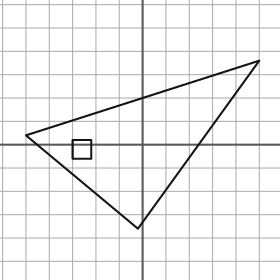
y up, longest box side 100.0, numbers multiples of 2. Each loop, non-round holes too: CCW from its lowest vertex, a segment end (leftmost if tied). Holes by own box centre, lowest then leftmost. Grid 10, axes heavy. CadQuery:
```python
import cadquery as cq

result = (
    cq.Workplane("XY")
    .moveTo(-2.0, -36.0)
    .lineTo(50.0, 36.0)
    .lineTo(-50.0, 4.0)
    .close()
    .moveTo(-30.0, -6.0)
    .lineTo(-22.0, -6.0)
    .lineTo(-22.0, 2.0)
    .lineTo(-30.0, 2.0)
    .close()
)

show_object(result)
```